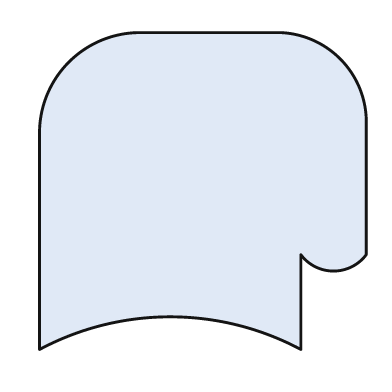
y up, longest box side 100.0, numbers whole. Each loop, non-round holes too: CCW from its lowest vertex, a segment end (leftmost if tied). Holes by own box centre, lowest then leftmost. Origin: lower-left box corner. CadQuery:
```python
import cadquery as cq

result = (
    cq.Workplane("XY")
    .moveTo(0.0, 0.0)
    .threePointArc((40.0, 10.0), (80.0, 0.0))
    .lineTo(80.0, 29.0)
    .threePointArc((90.0, 24.0), (100.0, 29.0))
    .lineTo(100.0, 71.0)
    .threePointArc((92.0, 89.0), (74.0, 97.0))
    .lineTo(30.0, 97.0)
    .threePointArc((9.0, 88.0), (0.0, 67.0))
    .close()
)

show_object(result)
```